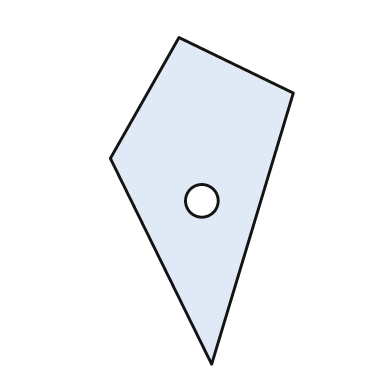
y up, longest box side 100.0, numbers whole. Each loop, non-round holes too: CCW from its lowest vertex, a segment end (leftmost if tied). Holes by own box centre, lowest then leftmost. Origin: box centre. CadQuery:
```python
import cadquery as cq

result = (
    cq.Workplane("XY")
    .moveTo(3.0, -50.0)
    .lineTo(28.0, 33.0)
    .lineTo(-7.0, 50.0)
    .lineTo(-28.0, 13.0)
    .close()
    .moveTo(0.0, 0.0)
    .circle(5.0)
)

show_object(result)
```